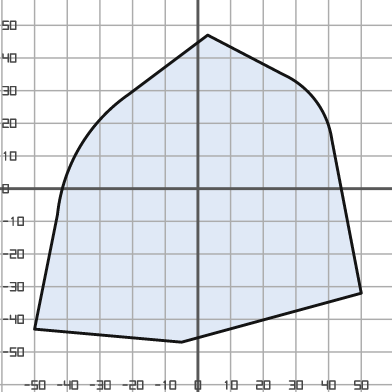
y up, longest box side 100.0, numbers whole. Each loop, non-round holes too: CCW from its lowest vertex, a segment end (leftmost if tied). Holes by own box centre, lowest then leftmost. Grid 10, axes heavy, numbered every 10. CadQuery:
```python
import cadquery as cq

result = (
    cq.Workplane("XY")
    .moveTo(-5.0, -47.0)
    .lineTo(50.0, -32.0)
    .lineTo(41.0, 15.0)
    .threePointArc((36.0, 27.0), (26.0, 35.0))
    .lineTo(3.0, 47.0)
    .lineTo(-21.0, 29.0)
    .threePointArc((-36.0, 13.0), (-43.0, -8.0))
    .lineTo(-50.0, -43.0)
    .close()
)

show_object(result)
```